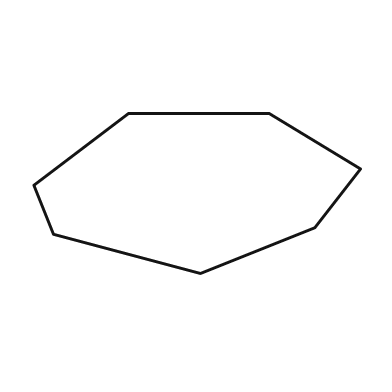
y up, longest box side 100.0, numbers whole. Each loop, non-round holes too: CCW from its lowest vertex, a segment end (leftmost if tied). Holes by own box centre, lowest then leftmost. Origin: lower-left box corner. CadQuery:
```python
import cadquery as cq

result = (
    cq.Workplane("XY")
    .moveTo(51.0, 0.0)
    .lineTo(86.0, 14.0)
    .lineTo(100.0, 32.0)
    .lineTo(72.0, 49.0)
    .lineTo(29.0, 49.0)
    .lineTo(0.0, 27.0)
    .lineTo(6.0, 12.0)
    .close()
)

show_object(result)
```